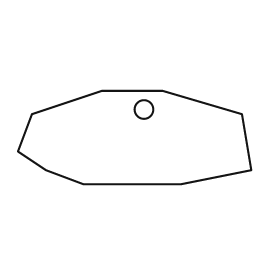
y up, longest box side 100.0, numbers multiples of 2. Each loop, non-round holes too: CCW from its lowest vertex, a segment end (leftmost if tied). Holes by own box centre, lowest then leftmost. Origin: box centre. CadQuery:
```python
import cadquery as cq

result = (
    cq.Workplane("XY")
    .moveTo(-22.0, -20.0)
    .lineTo(20.0, -20.0)
    .lineTo(50.0, -14.0)
    .lineTo(46.0, 10.0)
    .lineTo(12.0, 20.0)
    .lineTo(-14.0, 20.0)
    .lineTo(-44.0, 10.0)
    .lineTo(-50.0, -6.0)
    .lineTo(-38.0, -14.0)
    .close()
    .moveTo(4.0, 12.0)
    .circle(4.0)
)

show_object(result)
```